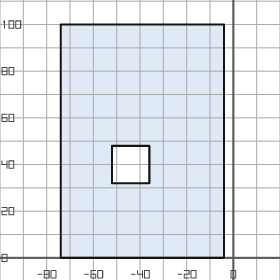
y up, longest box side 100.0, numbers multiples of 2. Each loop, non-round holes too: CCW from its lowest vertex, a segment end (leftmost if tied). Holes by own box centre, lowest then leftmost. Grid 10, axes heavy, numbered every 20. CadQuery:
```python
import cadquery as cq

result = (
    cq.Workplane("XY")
    .moveTo(-74.0, 0.0)
    .lineTo(-4.0, 0.0)
    .lineTo(-4.0, 100.0)
    .lineTo(-74.0, 100.0)
    .close()
    .moveTo(-52.0, 32.0)
    .lineTo(-36.0, 32.0)
    .lineTo(-36.0, 48.0)
    .lineTo(-52.0, 48.0)
    .close()
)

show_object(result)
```